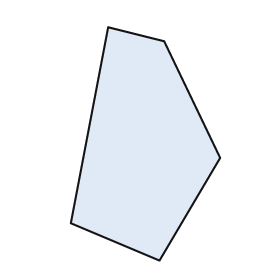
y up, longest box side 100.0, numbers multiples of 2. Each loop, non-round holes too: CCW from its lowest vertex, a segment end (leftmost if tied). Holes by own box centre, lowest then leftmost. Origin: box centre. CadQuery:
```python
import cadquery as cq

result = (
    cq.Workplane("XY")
    .moveTo(6.0, -50.0)
    .lineTo(32.0, -6.0)
    .lineTo(8.0, 44.0)
    .lineTo(-16.0, 50.0)
    .lineTo(-32.0, -34.0)
    .close()
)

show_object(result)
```